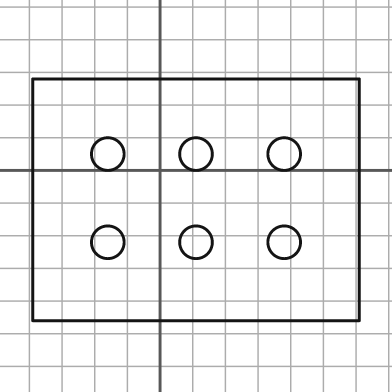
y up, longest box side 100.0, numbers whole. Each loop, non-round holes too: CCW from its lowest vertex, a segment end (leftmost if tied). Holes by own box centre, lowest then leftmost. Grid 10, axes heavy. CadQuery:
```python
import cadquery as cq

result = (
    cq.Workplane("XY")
    .moveTo(-39.0, -46.0)
    .lineTo(61.0, -46.0)
    .lineTo(61.0, 28.0)
    .lineTo(-39.0, 28.0)
    .close()
    .moveTo(-16.0, -22.0)
    .circle(5.0)
    .moveTo(11.0, -22.0)
    .circle(5.0)
    .moveTo(38.0, -22.0)
    .circle(5.0)
    .moveTo(-16.0, 5.0)
    .circle(5.0)
    .moveTo(11.0, 5.0)
    .circle(5.0)
    .moveTo(38.0, 5.0)
    .circle(5.0)
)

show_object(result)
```